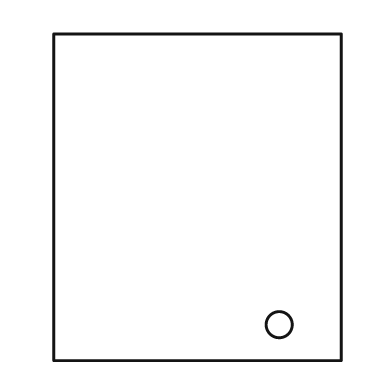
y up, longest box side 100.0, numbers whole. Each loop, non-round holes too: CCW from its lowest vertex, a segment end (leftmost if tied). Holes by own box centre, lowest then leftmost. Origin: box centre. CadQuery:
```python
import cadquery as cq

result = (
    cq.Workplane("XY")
    .moveTo(-44.0, -50.0)
    .lineTo(44.0, -50.0)
    .lineTo(44.0, 50.0)
    .lineTo(-44.0, 50.0)
    .close()
    .moveTo(25.0, -39.0)
    .circle(4.0)
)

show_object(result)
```